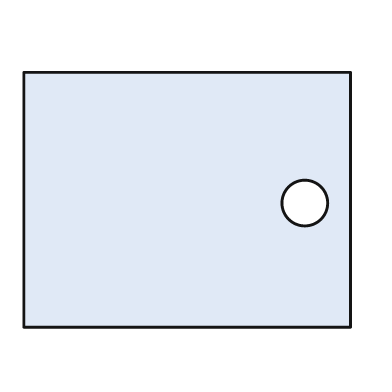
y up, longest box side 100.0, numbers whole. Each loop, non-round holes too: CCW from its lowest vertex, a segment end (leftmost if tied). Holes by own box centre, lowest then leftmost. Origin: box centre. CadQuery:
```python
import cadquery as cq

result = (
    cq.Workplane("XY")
    .moveTo(-50.0, -39.0)
    .lineTo(50.0, -39.0)
    .lineTo(50.0, 39.0)
    .lineTo(-50.0, 39.0)
    .close()
    .moveTo(36.0, -1.0)
    .circle(7.0)
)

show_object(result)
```